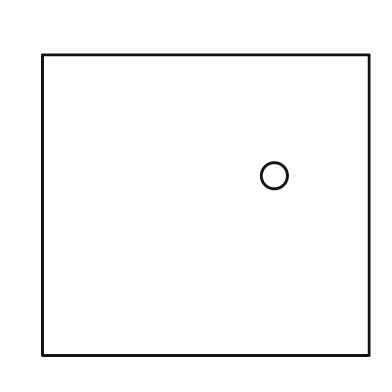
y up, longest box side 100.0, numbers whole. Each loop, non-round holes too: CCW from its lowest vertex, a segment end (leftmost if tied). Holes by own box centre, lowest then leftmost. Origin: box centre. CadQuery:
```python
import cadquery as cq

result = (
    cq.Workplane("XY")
    .moveTo(-50.0, -46.0)
    .lineTo(50.0, -46.0)
    .lineTo(50.0, 46.0)
    .lineTo(-50.0, 46.0)
    .close()
    .moveTo(21.0, 9.0)
    .circle(4.0)
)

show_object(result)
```